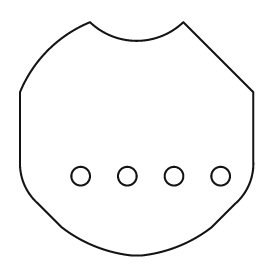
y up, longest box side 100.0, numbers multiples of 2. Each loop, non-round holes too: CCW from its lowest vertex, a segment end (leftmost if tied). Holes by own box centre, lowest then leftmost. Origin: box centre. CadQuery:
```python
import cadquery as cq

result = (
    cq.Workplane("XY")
    .moveTo(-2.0, -50.0)
    .lineTo(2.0, -50.0)
    .threePointArc((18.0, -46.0), (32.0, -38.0))
    .lineTo(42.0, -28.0)
    .threePointArc((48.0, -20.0), (50.0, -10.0))
    .lineTo(50.0, 20.0)
    .lineTo(20.0, 50.0)
    .threePointArc((0.0, 42.0), (-20.0, 50.0))
    .threePointArc((-38.0, 38.0), (-50.0, 20.0))
    .lineTo(-50.0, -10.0)
    .threePointArc((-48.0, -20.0), (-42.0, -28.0))
    .lineTo(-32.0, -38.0)
    .threePointArc((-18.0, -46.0), (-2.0, -50.0))
    .close()
    .moveTo(-24.0, -16.0)
    .circle(4.0)
    .moveTo(-4.0, -16.0)
    .circle(4.0)
    .moveTo(16.0, -16.0)
    .circle(4.0)
    .moveTo(36.0, -16.0)
    .circle(4.0)
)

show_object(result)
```